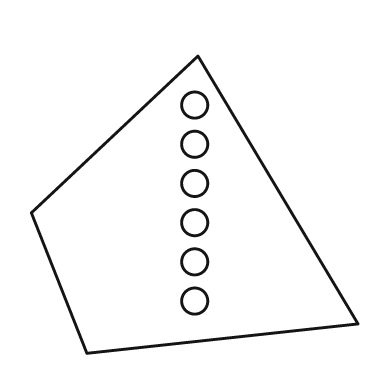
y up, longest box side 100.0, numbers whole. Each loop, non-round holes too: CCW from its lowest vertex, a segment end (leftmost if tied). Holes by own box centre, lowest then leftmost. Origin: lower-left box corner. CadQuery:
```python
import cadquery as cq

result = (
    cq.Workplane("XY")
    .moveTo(17.0, 0.0)
    .lineTo(100.0, 9.0)
    .lineTo(51.0, 91.0)
    .lineTo(0.0, 43.0)
    .close()
    .moveTo(50.0, 16.0)
    .circle(4.0)
    .moveTo(50.0, 28.0)
    .circle(4.0)
    .moveTo(50.0, 40.0)
    .circle(4.0)
    .moveTo(50.0, 52.0)
    .circle(4.0)
    .moveTo(50.0, 64.0)
    .circle(4.0)
    .moveTo(50.0, 76.0)
    .circle(4.0)
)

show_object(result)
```